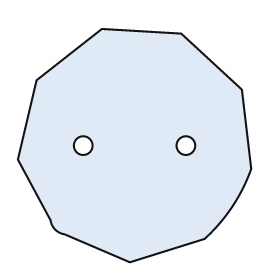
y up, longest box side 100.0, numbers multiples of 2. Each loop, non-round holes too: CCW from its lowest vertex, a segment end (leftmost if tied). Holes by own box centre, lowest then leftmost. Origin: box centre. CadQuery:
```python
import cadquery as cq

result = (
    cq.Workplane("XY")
    .moveTo(-2.0, -50.0)
    .lineTo(30.0, -40.0)
    .threePointArc((42.0, -26.0), (50.0, -10.0))
    .lineTo(46.0, 24.0)
    .lineTo(20.0, 48.0)
    .lineTo(-14.0, 50.0)
    .lineTo(-42.0, 28.0)
    .lineTo(-50.0, -6.0)
    .lineTo(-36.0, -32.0)
    .threePointArc((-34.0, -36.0), (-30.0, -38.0))
    .close()
    .moveTo(-22.0, 0.0)
    .circle(4.0)
    .moveTo(22.0, 0.0)
    .circle(4.0)
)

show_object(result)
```